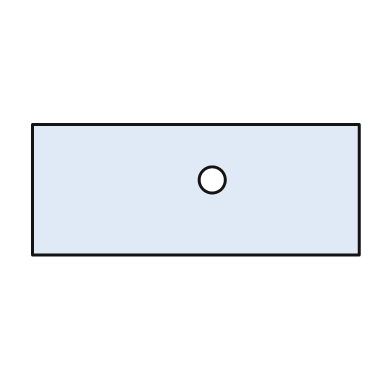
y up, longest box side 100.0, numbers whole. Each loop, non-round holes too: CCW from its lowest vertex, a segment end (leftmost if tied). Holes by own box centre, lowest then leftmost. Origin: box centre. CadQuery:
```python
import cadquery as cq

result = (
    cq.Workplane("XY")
    .moveTo(-50.0, -20.0)
    .lineTo(50.0, -20.0)
    .lineTo(50.0, 20.0)
    .lineTo(-50.0, 20.0)
    .close()
    .moveTo(5.0, 3.0)
    .circle(4.0)
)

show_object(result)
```